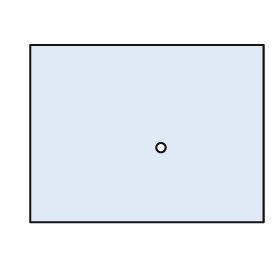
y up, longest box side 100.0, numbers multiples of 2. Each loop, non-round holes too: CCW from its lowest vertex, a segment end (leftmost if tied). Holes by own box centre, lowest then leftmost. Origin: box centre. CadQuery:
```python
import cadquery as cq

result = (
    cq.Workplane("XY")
    .moveTo(-50.0, -38.0)
    .lineTo(50.0, -38.0)
    .lineTo(50.0, 38.0)
    .lineTo(-50.0, 38.0)
    .close()
    .moveTo(6.0, -6.0)
    .circle(2.0)
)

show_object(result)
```